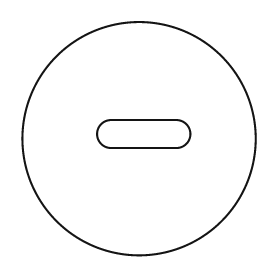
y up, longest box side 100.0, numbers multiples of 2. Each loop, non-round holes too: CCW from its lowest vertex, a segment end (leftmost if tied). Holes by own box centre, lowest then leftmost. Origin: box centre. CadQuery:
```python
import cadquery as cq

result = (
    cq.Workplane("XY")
    .moveTo(0.0, 0.0)
    .circle(50.0)
    .moveTo(-12.0, -4.0)
    .lineTo(16.0, -4.0)
    .threePointArc((22.0, 2.0), (16.0, 8.0))
    .lineTo(-12.0, 8.0)
    .threePointArc((-18.0, 2.0), (-12.0, -4.0))
    .close()
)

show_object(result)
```